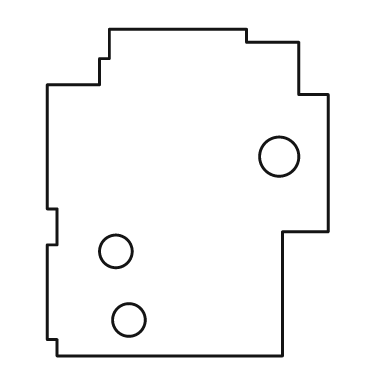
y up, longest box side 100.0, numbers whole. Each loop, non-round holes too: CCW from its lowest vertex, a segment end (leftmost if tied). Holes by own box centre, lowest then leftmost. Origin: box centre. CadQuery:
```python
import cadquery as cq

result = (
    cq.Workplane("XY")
    .moveTo(-40.0, -50.0)
    .lineTo(29.0, -50.0)
    .lineTo(29.0, -12.0)
    .lineTo(43.0, -12.0)
    .lineTo(43.0, 30.0)
    .lineTo(34.0, 30.0)
    .lineTo(34.0, 46.0)
    .lineTo(18.0, 46.0)
    .lineTo(18.0, 50.0)
    .lineTo(-24.0, 50.0)
    .lineTo(-24.0, 41.0)
    .lineTo(-27.0, 41.0)
    .lineTo(-27.0, 33.0)
    .lineTo(-43.0, 33.0)
    .lineTo(-43.0, -5.0)
    .lineTo(-40.0, -5.0)
    .lineTo(-40.0, -16.0)
    .lineTo(-43.0, -16.0)
    .lineTo(-43.0, -45.0)
    .lineTo(-40.0, -45.0)
    .close()
    .moveTo(-18.0, -39.0)
    .circle(5.0)
    .moveTo(-22.0, -18.0)
    .circle(5.0)
    .moveTo(28.0, 11.0)
    .circle(6.0)
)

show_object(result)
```